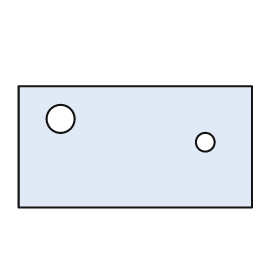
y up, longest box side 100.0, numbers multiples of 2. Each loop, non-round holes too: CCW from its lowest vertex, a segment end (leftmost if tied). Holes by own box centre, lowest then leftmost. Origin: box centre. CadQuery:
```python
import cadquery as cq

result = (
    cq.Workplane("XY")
    .moveTo(-50.0, -26.0)
    .lineTo(50.0, -26.0)
    .lineTo(50.0, 26.0)
    .lineTo(-50.0, 26.0)
    .close()
    .moveTo(30.0, 2.0)
    .circle(4.0)
    .moveTo(-32.0, 12.0)
    .circle(6.0)
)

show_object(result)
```